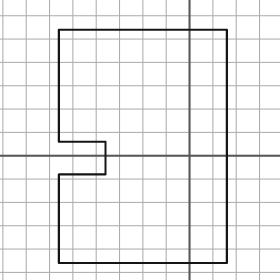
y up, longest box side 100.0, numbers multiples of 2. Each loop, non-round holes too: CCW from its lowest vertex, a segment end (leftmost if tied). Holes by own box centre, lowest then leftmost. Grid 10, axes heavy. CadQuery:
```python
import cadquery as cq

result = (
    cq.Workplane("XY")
    .moveTo(-56.0, -46.0)
    .lineTo(16.0, -46.0)
    .lineTo(16.0, 54.0)
    .lineTo(-56.0, 54.0)
    .lineTo(-56.0, 6.0)
    .lineTo(-36.0, 6.0)
    .lineTo(-36.0, -8.0)
    .lineTo(-56.0, -8.0)
    .close()
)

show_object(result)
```